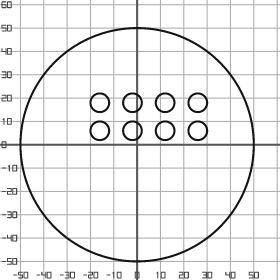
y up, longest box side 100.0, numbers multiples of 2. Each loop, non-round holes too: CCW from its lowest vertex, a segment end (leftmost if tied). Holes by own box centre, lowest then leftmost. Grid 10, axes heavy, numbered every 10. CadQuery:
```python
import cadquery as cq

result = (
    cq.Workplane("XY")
    .moveTo(0.0, 0.0)
    .circle(50.0)
    .moveTo(-16.0, 6.0)
    .circle(4.0)
    .moveTo(-2.0, 6.0)
    .circle(4.0)
    .moveTo(12.0, 6.0)
    .circle(4.0)
    .moveTo(26.0, 6.0)
    .circle(4.0)
    .moveTo(-16.0, 18.0)
    .circle(4.0)
    .moveTo(-2.0, 18.0)
    .circle(4.0)
    .moveTo(12.0, 18.0)
    .circle(4.0)
    .moveTo(26.0, 18.0)
    .circle(4.0)
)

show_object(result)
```